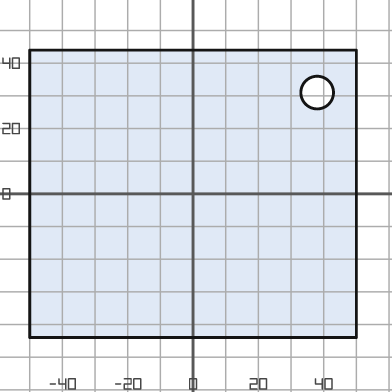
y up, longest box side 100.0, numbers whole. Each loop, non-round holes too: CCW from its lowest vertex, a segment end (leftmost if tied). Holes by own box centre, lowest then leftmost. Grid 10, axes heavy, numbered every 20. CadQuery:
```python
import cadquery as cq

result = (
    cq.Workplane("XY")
    .moveTo(-50.0, -44.0)
    .lineTo(50.0, -44.0)
    .lineTo(50.0, 44.0)
    .lineTo(-50.0, 44.0)
    .close()
    .moveTo(38.0, 31.0)
    .circle(5.0)
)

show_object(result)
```